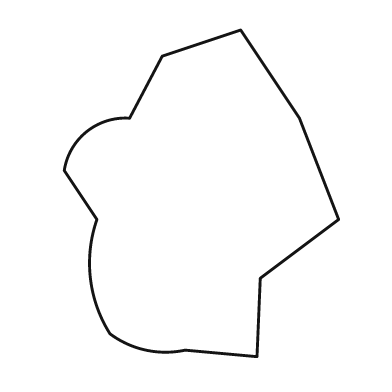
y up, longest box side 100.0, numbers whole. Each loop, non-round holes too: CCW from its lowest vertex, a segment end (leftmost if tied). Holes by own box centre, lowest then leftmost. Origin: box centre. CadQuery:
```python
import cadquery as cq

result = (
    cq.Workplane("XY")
    .moveTo(17.0, -50.0)
    .lineTo(18.0, -26.0)
    .lineTo(42.0, -8.0)
    .lineTo(30.0, 23.0)
    .lineTo(12.0, 50.0)
    .lineTo(-12.0, 42.0)
    .lineTo(-22.0, 23.0)
    .threePointArc((-35.0, 19.0), (-42.0, 7.0))
    .lineTo(-32.0, -8.0)
    .threePointArc((-34.0, -26.0), (-28.0, -43.0))
    .threePointArc((-17.0, -48.0), (-5.0, -48.0))
    .close()
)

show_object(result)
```